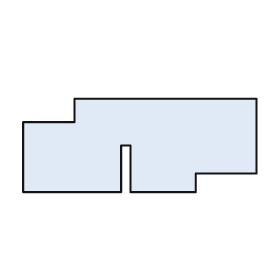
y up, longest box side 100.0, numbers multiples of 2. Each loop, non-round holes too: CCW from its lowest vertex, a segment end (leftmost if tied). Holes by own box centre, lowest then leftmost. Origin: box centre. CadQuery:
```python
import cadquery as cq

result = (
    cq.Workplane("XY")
    .moveTo(-50.0, -20.0)
    .lineTo(-8.0, -20.0)
    .lineTo(-8.0, 0.0)
    .lineTo(-4.0, 0.0)
    .lineTo(-4.0, -20.0)
    .lineTo(24.0, -20.0)
    .lineTo(24.0, -12.0)
    .lineTo(50.0, -12.0)
    .lineTo(50.0, 20.0)
    .lineTo(-28.0, 20.0)
    .lineTo(-28.0, 10.0)
    .lineTo(-50.0, 10.0)
    .close()
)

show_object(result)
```